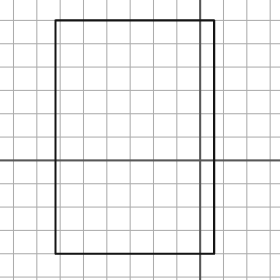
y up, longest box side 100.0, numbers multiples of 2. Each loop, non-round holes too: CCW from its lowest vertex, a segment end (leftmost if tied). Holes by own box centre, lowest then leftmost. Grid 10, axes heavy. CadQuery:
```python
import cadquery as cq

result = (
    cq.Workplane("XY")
    .moveTo(-62.0, -40.0)
    .lineTo(6.0, -40.0)
    .lineTo(6.0, 60.0)
    .lineTo(-62.0, 60.0)
    .close()
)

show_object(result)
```